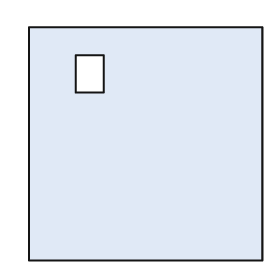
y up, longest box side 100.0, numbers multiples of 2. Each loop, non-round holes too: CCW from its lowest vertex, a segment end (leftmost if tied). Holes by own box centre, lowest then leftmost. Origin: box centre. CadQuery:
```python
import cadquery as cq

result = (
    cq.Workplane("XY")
    .moveTo(-50.0, -50.0)
    .lineTo(50.0, -50.0)
    .lineTo(50.0, 50.0)
    .lineTo(-50.0, 50.0)
    .close()
    .moveTo(-30.0, 22.0)
    .lineTo(-18.0, 22.0)
    .lineTo(-18.0, 38.0)
    .lineTo(-30.0, 38.0)
    .close()
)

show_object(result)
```